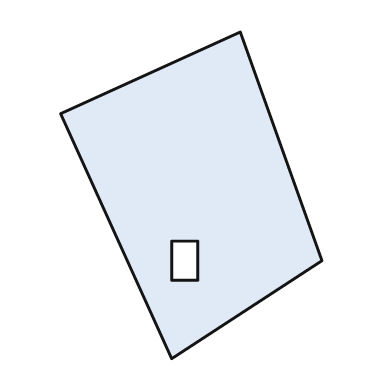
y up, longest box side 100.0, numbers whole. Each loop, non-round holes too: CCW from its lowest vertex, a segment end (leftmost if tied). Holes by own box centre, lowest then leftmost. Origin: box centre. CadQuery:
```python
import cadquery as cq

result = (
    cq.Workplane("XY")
    .moveTo(-6.0, -50.0)
    .lineTo(40.0, -20.0)
    .lineTo(15.0, 50.0)
    .lineTo(-40.0, 25.0)
    .close()
    .moveTo(-6.0, -26.0)
    .lineTo(2.0, -26.0)
    .lineTo(2.0, -14.0)
    .lineTo(-6.0, -14.0)
    .close()
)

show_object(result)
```